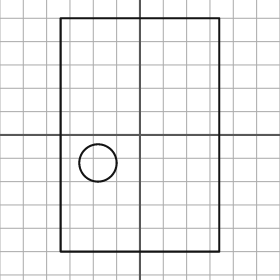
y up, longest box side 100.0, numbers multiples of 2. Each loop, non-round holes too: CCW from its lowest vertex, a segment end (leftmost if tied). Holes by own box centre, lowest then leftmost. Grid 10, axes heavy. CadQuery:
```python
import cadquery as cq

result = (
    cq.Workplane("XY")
    .moveTo(-34.0, -50.0)
    .lineTo(34.0, -50.0)
    .lineTo(34.0, 50.0)
    .lineTo(-34.0, 50.0)
    .close()
    .moveTo(-18.0, -12.0)
    .circle(8.0)
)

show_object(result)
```